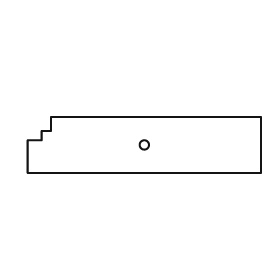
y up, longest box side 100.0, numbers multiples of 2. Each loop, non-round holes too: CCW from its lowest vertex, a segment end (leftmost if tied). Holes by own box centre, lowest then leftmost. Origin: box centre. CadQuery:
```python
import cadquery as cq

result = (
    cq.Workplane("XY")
    .moveTo(-50.0, -12.0)
    .lineTo(50.0, -12.0)
    .lineTo(50.0, 12.0)
    .lineTo(-40.0, 12.0)
    .lineTo(-40.0, 6.0)
    .lineTo(-44.0, 6.0)
    .lineTo(-44.0, 2.0)
    .lineTo(-50.0, 2.0)
    .close()
    .moveTo(0.0, 0.0)
    .circle(2.0)
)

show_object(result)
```